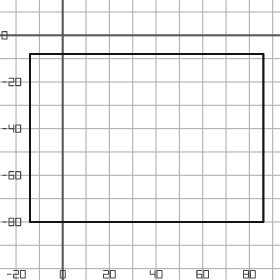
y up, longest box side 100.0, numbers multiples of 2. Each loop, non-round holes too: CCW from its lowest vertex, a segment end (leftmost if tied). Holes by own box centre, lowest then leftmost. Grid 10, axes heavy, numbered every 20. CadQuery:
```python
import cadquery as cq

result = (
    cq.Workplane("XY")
    .moveTo(-14.0, -80.0)
    .lineTo(86.0, -80.0)
    .lineTo(86.0, -8.0)
    .lineTo(-14.0, -8.0)
    .close()
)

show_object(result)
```